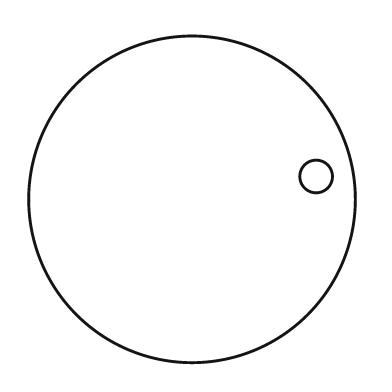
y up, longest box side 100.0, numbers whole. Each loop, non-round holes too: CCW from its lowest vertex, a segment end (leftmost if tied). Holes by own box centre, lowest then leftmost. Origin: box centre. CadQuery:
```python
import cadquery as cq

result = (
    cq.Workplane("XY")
    .moveTo(0.0, 0.0)
    .circle(50.0)
    .moveTo(38.0, 7.0)
    .circle(5.0)
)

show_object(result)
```